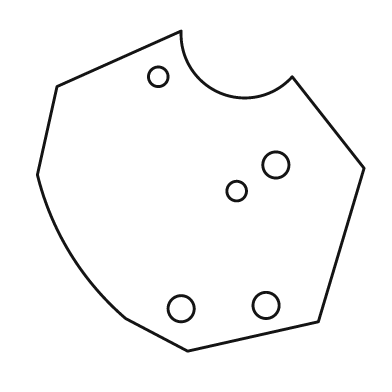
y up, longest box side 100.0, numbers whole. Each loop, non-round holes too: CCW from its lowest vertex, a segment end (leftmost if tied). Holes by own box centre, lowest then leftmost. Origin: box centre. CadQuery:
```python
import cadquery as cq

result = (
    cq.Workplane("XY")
    .moveTo(-4.0, -49.0)
    .lineTo(36.0, -40.0)
    .lineTo(50.0, 7.0)
    .lineTo(28.0, 35.0)
    .threePointArc((6.0, 30.0), (-6.0, 49.0))
    .lineTo(-44.0, 32.0)
    .lineTo(-50.0, 5.0)
    .threePointArc((-40.0, -19.0), (-23.0, -39.0))
    .close()
    .moveTo(-6.0, -36.0)
    .circle(4.0)
    .moveTo(20.0, -35.0)
    .circle(4.0)
    .moveTo(11.0, 0.0)
    .circle(3.0)
    .moveTo(23.0, 8.0)
    .circle(4.0)
    .moveTo(-13.0, 35.0)
    .circle(3.0)
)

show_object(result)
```